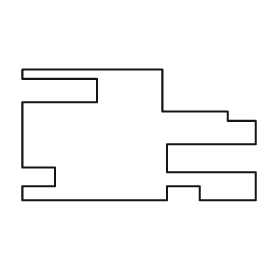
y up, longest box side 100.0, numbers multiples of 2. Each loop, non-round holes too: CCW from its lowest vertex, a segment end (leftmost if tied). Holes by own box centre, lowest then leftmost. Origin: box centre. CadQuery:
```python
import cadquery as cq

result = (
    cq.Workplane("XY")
    .moveTo(-50.0, -28.0)
    .lineTo(12.0, -28.0)
    .lineTo(12.0, -22.0)
    .lineTo(26.0, -22.0)
    .lineTo(26.0, -28.0)
    .lineTo(50.0, -28.0)
    .lineTo(50.0, -16.0)
    .lineTo(12.0, -16.0)
    .lineTo(12.0, -4.0)
    .lineTo(50.0, -4.0)
    .lineTo(50.0, 6.0)
    .lineTo(38.0, 6.0)
    .lineTo(38.0, 10.0)
    .lineTo(10.0, 10.0)
    .lineTo(10.0, 28.0)
    .lineTo(-50.0, 28.0)
    .lineTo(-50.0, 24.0)
    .lineTo(-18.0, 24.0)
    .lineTo(-18.0, 14.0)
    .lineTo(-50.0, 14.0)
    .lineTo(-50.0, -14.0)
    .lineTo(-36.0, -14.0)
    .lineTo(-36.0, -22.0)
    .lineTo(-50.0, -22.0)
    .close()
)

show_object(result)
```